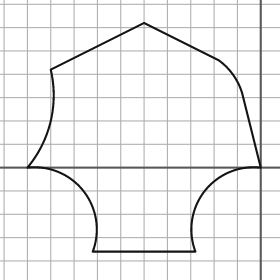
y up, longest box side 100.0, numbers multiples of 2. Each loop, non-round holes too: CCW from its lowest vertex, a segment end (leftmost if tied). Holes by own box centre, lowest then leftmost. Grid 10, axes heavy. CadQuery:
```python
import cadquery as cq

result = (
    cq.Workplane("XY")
    .moveTo(-72.0, -36.0)
    .lineTo(-28.0, -36.0)
    .threePointArc((-24.0, -10.0), (0.0, 0.0))
    .lineTo(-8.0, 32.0)
    .threePointArc((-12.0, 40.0), (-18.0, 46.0))
    .lineTo(-50.0, 62.0)
    .lineTo(-90.0, 42.0)
    .threePointArc((-90.0, 20.0), (-100.0, 0.0))
    .threePointArc((-76.0, -10.0), (-72.0, -36.0))
    .close()
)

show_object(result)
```